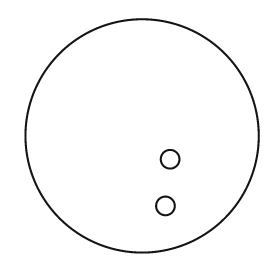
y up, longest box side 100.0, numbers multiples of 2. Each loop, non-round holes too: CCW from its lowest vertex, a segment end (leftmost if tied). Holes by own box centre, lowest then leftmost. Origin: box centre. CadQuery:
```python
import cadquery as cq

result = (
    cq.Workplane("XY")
    .moveTo(0.0, 0.0)
    .circle(50.0)
    .moveTo(10.0, -30.0)
    .circle(4.0)
    .moveTo(12.0, -10.0)
    .circle(4.0)
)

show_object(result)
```